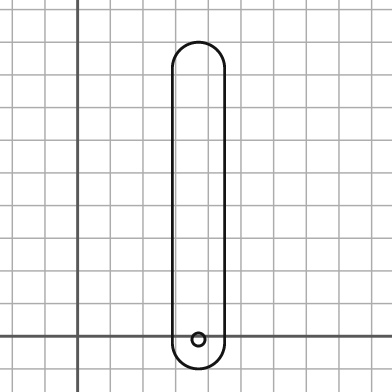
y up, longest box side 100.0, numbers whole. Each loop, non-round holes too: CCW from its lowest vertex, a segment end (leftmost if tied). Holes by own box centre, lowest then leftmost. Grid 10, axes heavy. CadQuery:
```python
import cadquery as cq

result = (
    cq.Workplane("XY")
    .moveTo(29.0, -2.0)
    .threePointArc((37.0, -10.0), (45.0, -2.0))
    .lineTo(45.0, 82.0)
    .threePointArc((37.0, 90.0), (29.0, 82.0))
    .close()
    .moveTo(37.0, -1.0)
    .circle(2.0)
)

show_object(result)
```